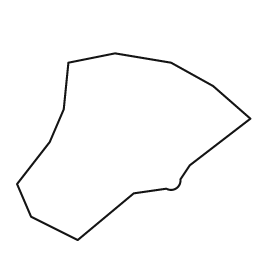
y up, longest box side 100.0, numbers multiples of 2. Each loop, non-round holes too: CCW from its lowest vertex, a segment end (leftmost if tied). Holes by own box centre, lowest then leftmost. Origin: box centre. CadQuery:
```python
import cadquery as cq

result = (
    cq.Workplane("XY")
    .moveTo(-24.0, -40.0)
    .lineTo(0.0, -20.0)
    .lineTo(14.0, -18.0)
    .threePointArc((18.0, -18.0), (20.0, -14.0))
    .lineTo(24.0, -8.0)
    .lineTo(50.0, 12.0)
    .lineTo(34.0, 26.0)
    .lineTo(16.0, 36.0)
    .lineTo(-8.0, 40.0)
    .lineTo(-28.0, 36.0)
    .lineTo(-30.0, 16.0)
    .lineTo(-36.0, 2.0)
    .lineTo(-50.0, -16.0)
    .lineTo(-44.0, -30.0)
    .close()
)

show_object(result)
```